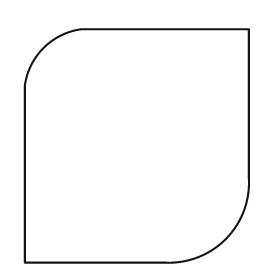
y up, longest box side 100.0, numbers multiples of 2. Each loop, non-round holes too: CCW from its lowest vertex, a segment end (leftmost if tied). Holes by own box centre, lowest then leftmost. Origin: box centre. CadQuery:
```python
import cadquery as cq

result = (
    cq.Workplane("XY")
    .moveTo(-48.0, -50.0)
    .lineTo(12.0, -50.0)
    .threePointArc((38.0, -40.0), (48.0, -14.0))
    .lineTo(48.0, 50.0)
    .lineTo(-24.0, 50.0)
    .threePointArc((-40.0, 42.0), (-48.0, 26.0))
    .close()
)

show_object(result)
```